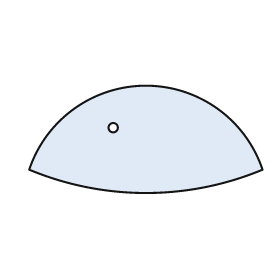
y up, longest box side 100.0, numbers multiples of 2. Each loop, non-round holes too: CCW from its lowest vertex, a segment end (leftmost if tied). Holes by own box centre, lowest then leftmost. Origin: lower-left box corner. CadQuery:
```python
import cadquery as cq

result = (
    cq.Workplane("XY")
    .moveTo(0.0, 10.0)
    .threePointArc((50.0, 0.0), (100.0, 10.0))
    .threePointArc((50.0, 46.0), (0.0, 10.0))
    .close()
    .moveTo(36.0, 28.0)
    .circle(2.0)
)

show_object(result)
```